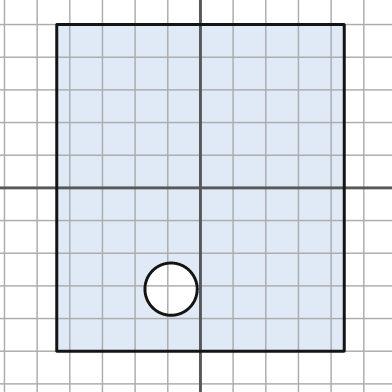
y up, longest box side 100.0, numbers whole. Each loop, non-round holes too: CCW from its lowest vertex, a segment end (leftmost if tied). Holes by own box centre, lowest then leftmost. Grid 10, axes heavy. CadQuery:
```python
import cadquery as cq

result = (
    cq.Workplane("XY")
    .moveTo(-44.0, -50.0)
    .lineTo(44.0, -50.0)
    .lineTo(44.0, 50.0)
    .lineTo(-44.0, 50.0)
    .close()
    .moveTo(-9.0, -31.0)
    .circle(8.0)
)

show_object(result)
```